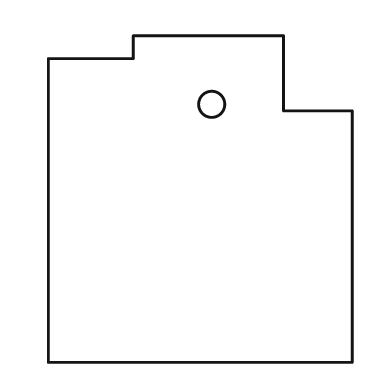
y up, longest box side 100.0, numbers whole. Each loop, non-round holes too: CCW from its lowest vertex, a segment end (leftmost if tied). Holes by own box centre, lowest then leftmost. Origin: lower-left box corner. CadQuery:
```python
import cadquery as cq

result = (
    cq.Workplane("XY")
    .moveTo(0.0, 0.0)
    .lineTo(93.0, 0.0)
    .lineTo(93.0, 77.0)
    .lineTo(72.0, 77.0)
    .lineTo(72.0, 100.0)
    .lineTo(26.0, 100.0)
    .lineTo(26.0, 93.0)
    .lineTo(0.0, 93.0)
    .close()
    .moveTo(50.0, 79.0)
    .circle(4.0)
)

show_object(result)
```